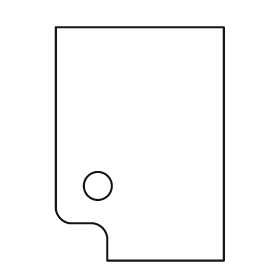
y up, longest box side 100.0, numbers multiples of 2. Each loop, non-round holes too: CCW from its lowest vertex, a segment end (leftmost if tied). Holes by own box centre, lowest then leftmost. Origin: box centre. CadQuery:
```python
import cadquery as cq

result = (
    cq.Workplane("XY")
    .moveTo(-14.0, -50.0)
    .lineTo(36.0, -50.0)
    .lineTo(36.0, 50.0)
    .lineTo(-36.0, 50.0)
    .lineTo(-36.0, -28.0)
    .threePointArc((-34.0, -32.0), (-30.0, -34.0))
    .lineTo(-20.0, -34.0)
    .threePointArc((-16.0, -36.0), (-14.0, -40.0))
    .close()
    .moveTo(-18.0, -18.0)
    .circle(6.0)
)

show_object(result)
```